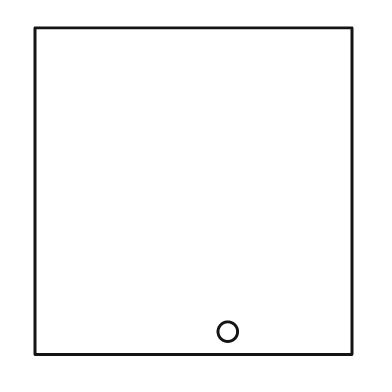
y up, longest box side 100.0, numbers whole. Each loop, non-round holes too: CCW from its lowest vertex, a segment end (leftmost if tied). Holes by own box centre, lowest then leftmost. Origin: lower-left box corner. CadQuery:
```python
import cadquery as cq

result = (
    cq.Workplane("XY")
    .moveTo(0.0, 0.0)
    .lineTo(97.0, 0.0)
    .lineTo(97.0, 100.0)
    .lineTo(0.0, 100.0)
    .close()
    .moveTo(59.0, 7.0)
    .circle(3.0)
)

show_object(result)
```